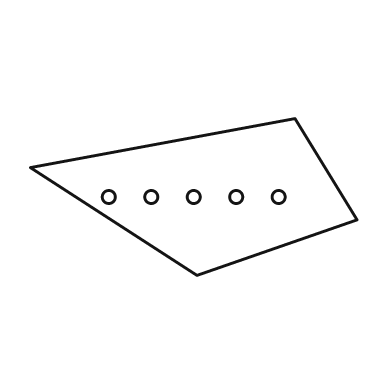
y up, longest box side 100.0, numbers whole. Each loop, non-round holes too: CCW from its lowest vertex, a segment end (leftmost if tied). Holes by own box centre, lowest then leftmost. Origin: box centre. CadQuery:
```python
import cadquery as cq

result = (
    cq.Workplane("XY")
    .moveTo(1.0, -24.0)
    .lineTo(50.0, -7.0)
    .lineTo(31.0, 24.0)
    .lineTo(-50.0, 9.0)
    .close()
    .moveTo(-26.0, 0.0)
    .circle(2.0)
    .moveTo(-13.0, 0.0)
    .circle(2.0)
    .moveTo(0.0, 0.0)
    .circle(2.0)
    .moveTo(13.0, 0.0)
    .circle(2.0)
    .moveTo(26.0, 0.0)
    .circle(2.0)
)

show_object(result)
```